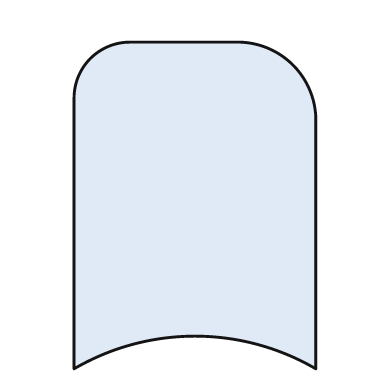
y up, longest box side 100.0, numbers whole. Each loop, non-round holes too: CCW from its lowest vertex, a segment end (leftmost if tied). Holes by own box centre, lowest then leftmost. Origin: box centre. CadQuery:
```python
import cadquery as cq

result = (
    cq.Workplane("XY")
    .moveTo(-37.0, -50.0)
    .threePointArc((0.0, -40.0), (37.0, -50.0))
    .lineTo(37.0, 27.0)
    .threePointArc((30.0, 43.0), (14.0, 50.0))
    .lineTo(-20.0, 50.0)
    .threePointArc((-32.0, 45.0), (-37.0, 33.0))
    .close()
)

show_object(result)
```